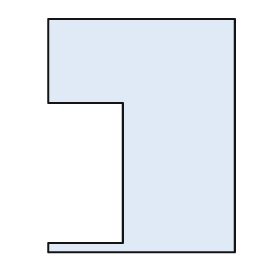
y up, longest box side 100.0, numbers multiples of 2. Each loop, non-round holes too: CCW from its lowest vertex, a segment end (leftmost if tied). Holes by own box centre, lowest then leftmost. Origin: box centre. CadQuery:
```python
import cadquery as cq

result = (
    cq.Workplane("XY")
    .moveTo(-40.0, -50.0)
    .lineTo(40.0, -50.0)
    .lineTo(40.0, 50.0)
    .lineTo(-40.0, 50.0)
    .lineTo(-40.0, 14.0)
    .lineTo(-8.0, 14.0)
    .lineTo(-8.0, -46.0)
    .lineTo(-40.0, -46.0)
    .close()
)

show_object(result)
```